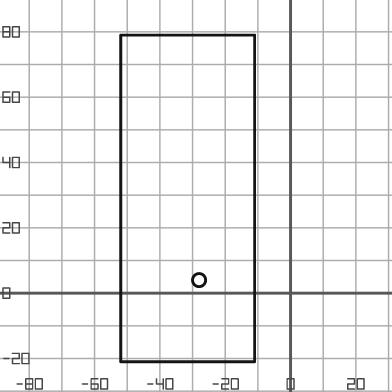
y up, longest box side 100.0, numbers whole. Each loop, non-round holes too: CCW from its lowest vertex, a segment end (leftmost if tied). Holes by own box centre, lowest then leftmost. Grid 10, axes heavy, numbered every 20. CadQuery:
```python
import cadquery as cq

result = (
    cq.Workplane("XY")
    .moveTo(-52.0, -21.0)
    .lineTo(-11.0, -21.0)
    .lineTo(-11.0, 79.0)
    .lineTo(-52.0, 79.0)
    .close()
    .moveTo(-28.0, 4.0)
    .circle(2.0)
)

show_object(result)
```